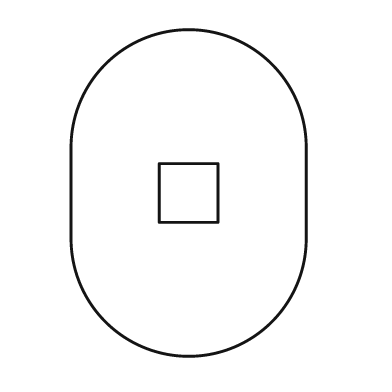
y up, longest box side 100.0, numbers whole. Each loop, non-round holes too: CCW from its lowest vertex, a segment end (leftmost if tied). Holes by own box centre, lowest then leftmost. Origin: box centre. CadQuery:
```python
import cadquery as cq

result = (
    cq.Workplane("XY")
    .moveTo(-36.0, -14.0)
    .threePointArc((0.0, -50.0), (36.0, -14.0))
    .lineTo(36.0, 14.0)
    .threePointArc((0.0, 50.0), (-36.0, 14.0))
    .close()
    .moveTo(-9.0, -9.0)
    .lineTo(9.0, -9.0)
    .lineTo(9.0, 9.0)
    .lineTo(-9.0, 9.0)
    .close()
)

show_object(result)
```